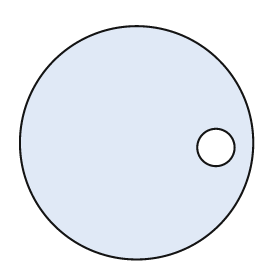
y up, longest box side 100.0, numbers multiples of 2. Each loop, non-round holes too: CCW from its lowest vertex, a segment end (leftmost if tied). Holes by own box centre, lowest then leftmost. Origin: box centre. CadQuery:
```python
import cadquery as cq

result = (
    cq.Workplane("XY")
    .moveTo(0.0, 0.0)
    .circle(50.0)
    .moveTo(34.0, -2.0)
    .circle(8.0)
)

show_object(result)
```